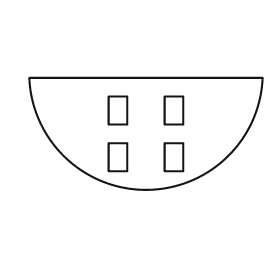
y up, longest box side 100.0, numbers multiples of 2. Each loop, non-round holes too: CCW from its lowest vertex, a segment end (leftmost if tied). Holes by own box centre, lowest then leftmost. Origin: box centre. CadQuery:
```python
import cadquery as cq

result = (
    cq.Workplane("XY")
    .moveTo(-50.0, 24.0)
    .threePointArc((0.0, -24.0), (50.0, 24.0))
    .close()
    .moveTo(-16.0, -16.0)
    .lineTo(-8.0, -16.0)
    .lineTo(-8.0, -4.0)
    .lineTo(-16.0, -4.0)
    .close()
    .moveTo(8.0, -16.0)
    .lineTo(16.0, -16.0)
    .lineTo(16.0, -4.0)
    .lineTo(8.0, -4.0)
    .close()
    .moveTo(-16.0, 4.0)
    .lineTo(-8.0, 4.0)
    .lineTo(-8.0, 16.0)
    .lineTo(-16.0, 16.0)
    .close()
    .moveTo(8.0, 4.0)
    .lineTo(16.0, 4.0)
    .lineTo(16.0, 16.0)
    .lineTo(8.0, 16.0)
    .close()
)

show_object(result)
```